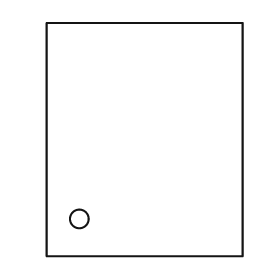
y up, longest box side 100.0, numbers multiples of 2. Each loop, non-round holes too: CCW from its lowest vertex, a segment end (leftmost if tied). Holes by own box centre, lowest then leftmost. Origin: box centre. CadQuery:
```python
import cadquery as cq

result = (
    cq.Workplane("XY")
    .moveTo(-42.0, -50.0)
    .lineTo(42.0, -50.0)
    .lineTo(42.0, 50.0)
    .lineTo(-42.0, 50.0)
    .close()
    .moveTo(-28.0, -34.0)
    .circle(4.0)
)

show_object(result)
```